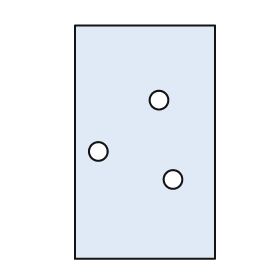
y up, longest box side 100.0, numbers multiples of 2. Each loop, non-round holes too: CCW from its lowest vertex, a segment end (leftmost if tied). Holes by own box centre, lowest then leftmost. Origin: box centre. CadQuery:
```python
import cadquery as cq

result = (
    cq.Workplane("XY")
    .moveTo(-30.0, -50.0)
    .lineTo(30.0, -50.0)
    .lineTo(30.0, 50.0)
    .lineTo(-30.0, 50.0)
    .close()
    .moveTo(12.0, -16.0)
    .circle(4.0)
    .moveTo(-20.0, -4.0)
    .circle(4.0)
    .moveTo(6.0, 18.0)
    .circle(4.0)
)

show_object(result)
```